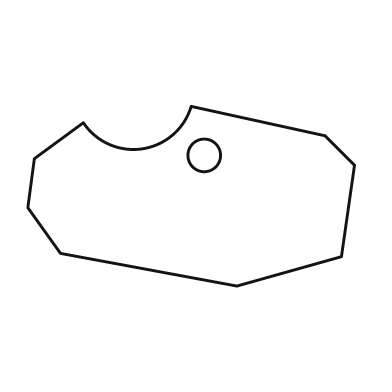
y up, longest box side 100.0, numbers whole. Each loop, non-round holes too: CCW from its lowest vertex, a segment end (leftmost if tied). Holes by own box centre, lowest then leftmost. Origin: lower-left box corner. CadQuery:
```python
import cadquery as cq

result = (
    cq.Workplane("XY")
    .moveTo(64.0, 0.0)
    .lineTo(96.0, 9.0)
    .lineTo(100.0, 37.0)
    .lineTo(91.0, 46.0)
    .lineTo(50.0, 55.0)
    .threePointArc((35.0, 42.0), (17.0, 50.0))
    .lineTo(2.0, 39.0)
    .lineTo(0.0, 24.0)
    .lineTo(10.0, 10.0)
    .close()
    .moveTo(54.0, 40.0)
    .circle(5.0)
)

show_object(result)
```